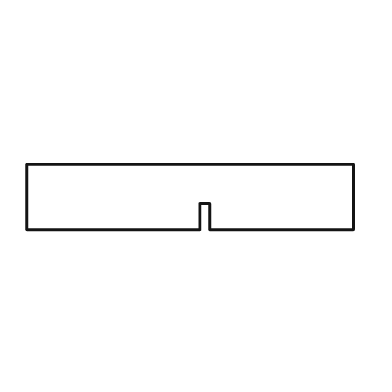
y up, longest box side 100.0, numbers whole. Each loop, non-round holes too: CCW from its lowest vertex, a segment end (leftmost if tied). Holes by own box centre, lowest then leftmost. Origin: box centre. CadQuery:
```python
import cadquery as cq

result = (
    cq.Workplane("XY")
    .moveTo(-50.0, -10.0)
    .lineTo(3.0, -10.0)
    .lineTo(3.0, -2.0)
    .lineTo(6.0, -2.0)
    .lineTo(6.0, -10.0)
    .lineTo(50.0, -10.0)
    .lineTo(50.0, 10.0)
    .lineTo(-50.0, 10.0)
    .close()
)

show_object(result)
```